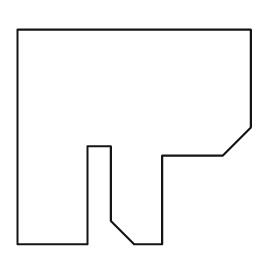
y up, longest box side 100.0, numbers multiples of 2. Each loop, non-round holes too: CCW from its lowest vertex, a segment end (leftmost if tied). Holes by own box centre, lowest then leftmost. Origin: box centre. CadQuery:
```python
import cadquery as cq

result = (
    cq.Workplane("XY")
    .moveTo(-50.0, -46.0)
    .lineTo(-20.0, -46.0)
    .lineTo(-20.0, -4.0)
    .lineTo(-10.0, -4.0)
    .lineTo(-10.0, -36.0)
    .lineTo(0.0, -46.0)
    .lineTo(12.0, -46.0)
    .lineTo(12.0, -8.0)
    .lineTo(38.0, -8.0)
    .lineTo(50.0, 4.0)
    .lineTo(50.0, 46.0)
    .lineTo(-50.0, 46.0)
    .close()
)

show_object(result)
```